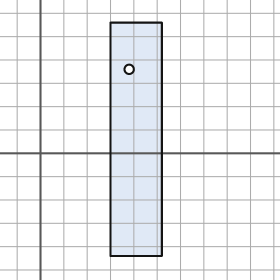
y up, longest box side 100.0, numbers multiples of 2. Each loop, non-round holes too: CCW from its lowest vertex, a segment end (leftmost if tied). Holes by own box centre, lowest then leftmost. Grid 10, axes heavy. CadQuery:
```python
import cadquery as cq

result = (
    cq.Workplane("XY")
    .moveTo(30.0, -44.0)
    .lineTo(52.0, -44.0)
    .lineTo(52.0, 56.0)
    .lineTo(30.0, 56.0)
    .close()
    .moveTo(38.0, 36.0)
    .circle(2.0)
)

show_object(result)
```